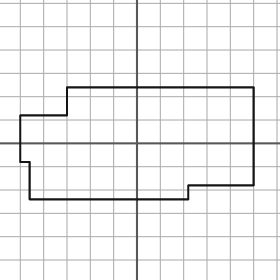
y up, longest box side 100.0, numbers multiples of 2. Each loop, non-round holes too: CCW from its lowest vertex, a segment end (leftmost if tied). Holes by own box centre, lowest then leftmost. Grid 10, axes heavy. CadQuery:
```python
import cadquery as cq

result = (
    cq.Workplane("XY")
    .moveTo(-46.0, -24.0)
    .lineTo(22.0, -24.0)
    .lineTo(22.0, -18.0)
    .lineTo(50.0, -18.0)
    .lineTo(50.0, 24.0)
    .lineTo(-30.0, 24.0)
    .lineTo(-30.0, 12.0)
    .lineTo(-50.0, 12.0)
    .lineTo(-50.0, -8.0)
    .lineTo(-46.0, -8.0)
    .close()
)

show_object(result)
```